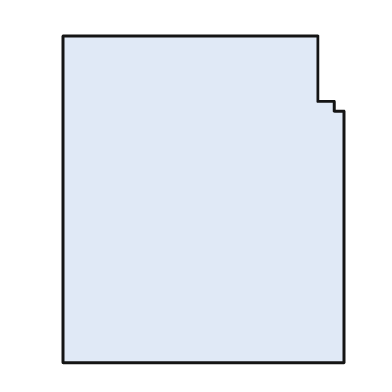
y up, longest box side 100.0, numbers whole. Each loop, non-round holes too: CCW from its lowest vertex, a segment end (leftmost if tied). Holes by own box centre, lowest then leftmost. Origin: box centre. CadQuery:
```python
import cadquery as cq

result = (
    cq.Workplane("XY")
    .moveTo(-43.0, -50.0)
    .lineTo(43.0, -50.0)
    .lineTo(43.0, 27.0)
    .lineTo(40.0, 27.0)
    .lineTo(40.0, 30.0)
    .lineTo(35.0, 30.0)
    .lineTo(35.0, 50.0)
    .lineTo(-43.0, 50.0)
    .close()
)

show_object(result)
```